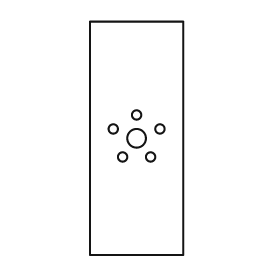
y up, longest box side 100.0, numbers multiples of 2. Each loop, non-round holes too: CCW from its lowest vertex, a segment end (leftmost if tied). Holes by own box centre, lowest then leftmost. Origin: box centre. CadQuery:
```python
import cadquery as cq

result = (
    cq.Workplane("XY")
    .moveTo(-20.0, -50.0)
    .lineTo(20.0, -50.0)
    .lineTo(20.0, 50.0)
    .lineTo(-20.0, 50.0)
    .close()
    .moveTo(-6.0, -8.0)
    .circle(2.0)
    .moveTo(6.0, -8.0)
    .circle(2.0)
    .moveTo(0.0, 0.0)
    .circle(4.0)
    .moveTo(-10.0, 4.0)
    .circle(2.0)
    .moveTo(10.0, 4.0)
    .circle(2.0)
    .moveTo(0.0, 10.0)
    .circle(2.0)
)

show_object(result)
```